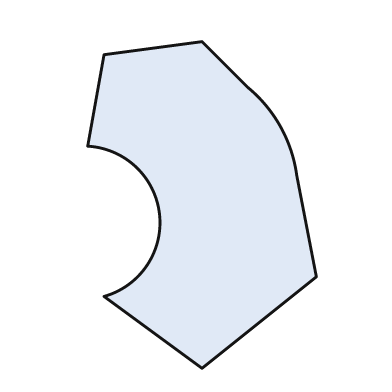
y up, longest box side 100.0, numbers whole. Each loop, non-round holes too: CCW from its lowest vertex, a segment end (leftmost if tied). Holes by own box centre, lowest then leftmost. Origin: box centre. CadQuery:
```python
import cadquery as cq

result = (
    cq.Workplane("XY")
    .moveTo(0.0, -50.0)
    .lineTo(35.0, -22.0)
    .lineTo(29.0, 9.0)
    .threePointArc((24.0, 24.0), (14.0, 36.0))
    .lineTo(0.0, 50.0)
    .lineTo(-30.0, 46.0)
    .lineTo(-35.0, 18.0)
    .threePointArc((-13.0, -3.0), (-30.0, -28.0))
    .close()
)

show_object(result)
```